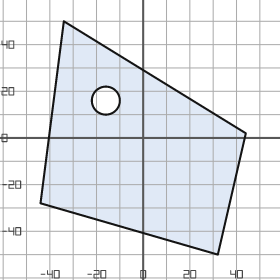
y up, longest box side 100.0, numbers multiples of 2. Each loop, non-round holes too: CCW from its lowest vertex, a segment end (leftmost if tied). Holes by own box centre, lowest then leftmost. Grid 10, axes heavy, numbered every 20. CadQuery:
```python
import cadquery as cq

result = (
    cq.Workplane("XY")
    .moveTo(32.0, -50.0)
    .lineTo(44.0, 2.0)
    .lineTo(-34.0, 50.0)
    .lineTo(-44.0, -28.0)
    .close()
    .moveTo(-16.0, 16.0)
    .circle(6.0)
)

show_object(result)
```